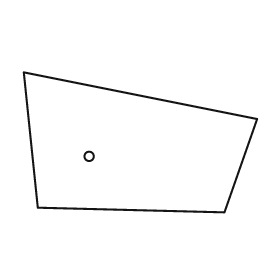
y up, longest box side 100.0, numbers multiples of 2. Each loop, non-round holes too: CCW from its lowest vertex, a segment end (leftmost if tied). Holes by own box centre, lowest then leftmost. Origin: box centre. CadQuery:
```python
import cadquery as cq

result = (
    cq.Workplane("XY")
    .moveTo(36.0, -30.0)
    .lineTo(50.0, 10.0)
    .lineTo(-50.0, 30.0)
    .lineTo(-44.0, -28.0)
    .close()
    .moveTo(-22.0, -6.0)
    .circle(2.0)
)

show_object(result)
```